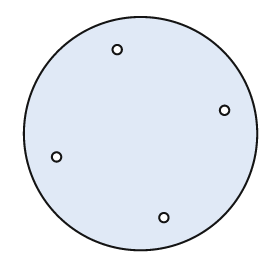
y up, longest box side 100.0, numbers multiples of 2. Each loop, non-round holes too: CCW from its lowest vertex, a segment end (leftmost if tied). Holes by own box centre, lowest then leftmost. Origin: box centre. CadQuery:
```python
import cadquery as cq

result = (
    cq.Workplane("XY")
    .moveTo(0.0, 0.0)
    .circle(50.0)
    .moveTo(10.0, -36.0)
    .circle(2.0)
    .moveTo(-36.0, -10.0)
    .circle(2.0)
    .moveTo(36.0, 10.0)
    .circle(2.0)
    .moveTo(-10.0, 36.0)
    .circle(2.0)
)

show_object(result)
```